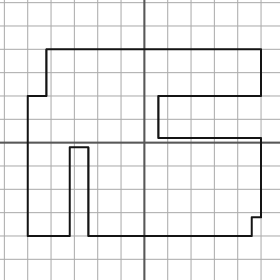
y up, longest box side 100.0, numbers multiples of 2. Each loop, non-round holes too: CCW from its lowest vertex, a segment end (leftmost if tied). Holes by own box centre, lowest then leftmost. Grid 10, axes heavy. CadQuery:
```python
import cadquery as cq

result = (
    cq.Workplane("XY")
    .moveTo(-50.0, -40.0)
    .lineTo(-32.0, -40.0)
    .lineTo(-32.0, -2.0)
    .lineTo(-24.0, -2.0)
    .lineTo(-24.0, -40.0)
    .lineTo(46.0, -40.0)
    .lineTo(46.0, -32.0)
    .lineTo(50.0, -32.0)
    .lineTo(50.0, 2.0)
    .lineTo(6.0, 2.0)
    .lineTo(6.0, 20.0)
    .lineTo(50.0, 20.0)
    .lineTo(50.0, 40.0)
    .lineTo(-42.0, 40.0)
    .lineTo(-42.0, 20.0)
    .lineTo(-50.0, 20.0)
    .close()
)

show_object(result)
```